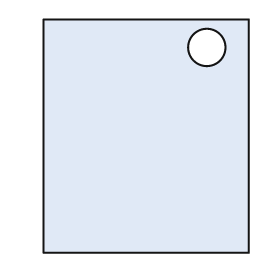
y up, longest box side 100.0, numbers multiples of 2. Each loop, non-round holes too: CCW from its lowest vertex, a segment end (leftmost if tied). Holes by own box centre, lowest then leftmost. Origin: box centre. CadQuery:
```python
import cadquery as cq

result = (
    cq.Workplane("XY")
    .moveTo(-44.0, -50.0)
    .lineTo(44.0, -50.0)
    .lineTo(44.0, 50.0)
    .lineTo(-44.0, 50.0)
    .close()
    .moveTo(26.0, 38.0)
    .circle(8.0)
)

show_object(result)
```